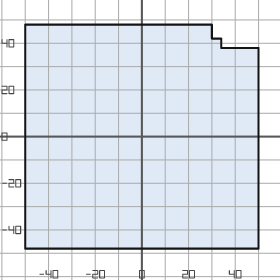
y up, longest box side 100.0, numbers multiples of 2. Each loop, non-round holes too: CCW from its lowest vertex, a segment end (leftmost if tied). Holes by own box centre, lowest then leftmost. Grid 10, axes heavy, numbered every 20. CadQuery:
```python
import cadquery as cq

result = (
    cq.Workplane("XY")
    .moveTo(-50.0, -48.0)
    .lineTo(50.0, -48.0)
    .lineTo(50.0, 38.0)
    .lineTo(34.0, 38.0)
    .lineTo(34.0, 42.0)
    .lineTo(30.0, 42.0)
    .lineTo(30.0, 48.0)
    .lineTo(-50.0, 48.0)
    .close()
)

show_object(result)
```